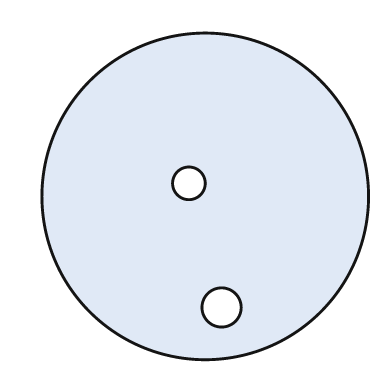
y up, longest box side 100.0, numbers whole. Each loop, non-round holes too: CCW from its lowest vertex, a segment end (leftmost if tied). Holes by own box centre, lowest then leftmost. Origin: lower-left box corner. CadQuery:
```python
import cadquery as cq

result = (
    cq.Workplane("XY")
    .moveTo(50.0, 50.0)
    .circle(50.0)
    .moveTo(55.0, 16.0)
    .circle(6.0)
    .moveTo(45.0, 54.0)
    .circle(5.0)
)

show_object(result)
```